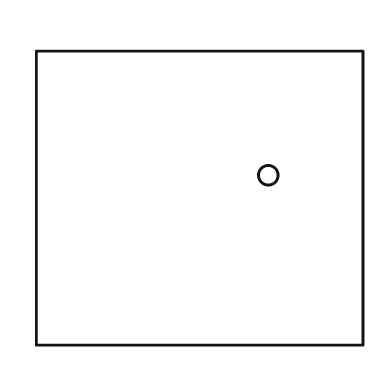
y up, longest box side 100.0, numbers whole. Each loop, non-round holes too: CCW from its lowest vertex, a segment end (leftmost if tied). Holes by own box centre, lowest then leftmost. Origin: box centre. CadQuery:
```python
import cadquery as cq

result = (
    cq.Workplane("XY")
    .moveTo(-50.0, -45.0)
    .lineTo(50.0, -45.0)
    .lineTo(50.0, 45.0)
    .lineTo(-50.0, 45.0)
    .close()
    .moveTo(21.0, 7.0)
    .circle(3.0)
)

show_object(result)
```